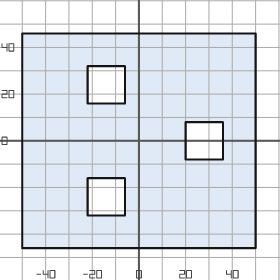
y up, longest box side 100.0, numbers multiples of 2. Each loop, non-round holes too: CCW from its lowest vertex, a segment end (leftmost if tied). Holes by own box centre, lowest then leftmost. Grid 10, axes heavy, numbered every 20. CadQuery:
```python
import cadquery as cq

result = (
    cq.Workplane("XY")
    .moveTo(-50.0, -46.0)
    .lineTo(50.0, -46.0)
    .lineTo(50.0, 46.0)
    .lineTo(-50.0, 46.0)
    .close()
    .moveTo(-22.0, -32.0)
    .lineTo(-6.0, -32.0)
    .lineTo(-6.0, -16.0)
    .lineTo(-22.0, -16.0)
    .close()
    .moveTo(20.0, -8.0)
    .lineTo(36.0, -8.0)
    .lineTo(36.0, 8.0)
    .lineTo(20.0, 8.0)
    .close()
    .moveTo(-22.0, 16.0)
    .lineTo(-6.0, 16.0)
    .lineTo(-6.0, 32.0)
    .lineTo(-22.0, 32.0)
    .close()
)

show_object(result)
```